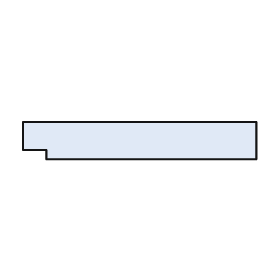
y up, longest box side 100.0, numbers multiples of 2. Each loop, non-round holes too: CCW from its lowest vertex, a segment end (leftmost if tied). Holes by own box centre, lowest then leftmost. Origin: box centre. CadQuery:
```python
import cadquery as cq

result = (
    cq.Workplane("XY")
    .moveTo(-40.0, -8.0)
    .lineTo(50.0, -8.0)
    .lineTo(50.0, 8.0)
    .lineTo(-50.0, 8.0)
    .lineTo(-50.0, -4.0)
    .lineTo(-40.0, -4.0)
    .close()
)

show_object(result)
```